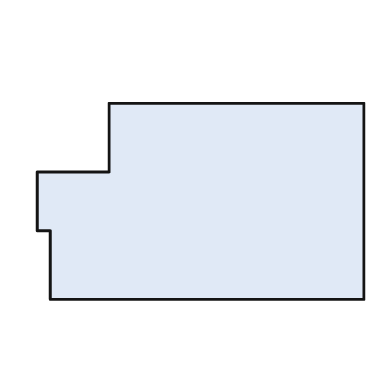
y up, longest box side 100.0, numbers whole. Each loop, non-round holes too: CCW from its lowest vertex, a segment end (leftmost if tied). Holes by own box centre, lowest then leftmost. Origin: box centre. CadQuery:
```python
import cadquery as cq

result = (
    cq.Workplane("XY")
    .moveTo(-46.0, -30.0)
    .lineTo(50.0, -30.0)
    .lineTo(50.0, 30.0)
    .lineTo(-28.0, 30.0)
    .lineTo(-28.0, 9.0)
    .lineTo(-50.0, 9.0)
    .lineTo(-50.0, -9.0)
    .lineTo(-46.0, -9.0)
    .close()
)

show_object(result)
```